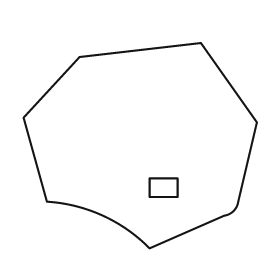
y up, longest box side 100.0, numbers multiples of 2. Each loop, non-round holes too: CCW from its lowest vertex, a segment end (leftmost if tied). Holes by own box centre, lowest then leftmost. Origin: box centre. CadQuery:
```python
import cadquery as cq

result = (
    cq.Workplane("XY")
    .moveTo(4.0, -44.0)
    .lineTo(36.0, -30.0)
    .threePointArc((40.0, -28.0), (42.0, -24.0))
    .lineTo(50.0, 10.0)
    .lineTo(26.0, 44.0)
    .lineTo(-26.0, 38.0)
    .lineTo(-50.0, 12.0)
    .lineTo(-40.0, -24.0)
    .threePointArc((-16.0, -30.0), (4.0, -44.0))
    .close()
    .moveTo(4.0, -22.0)
    .lineTo(16.0, -22.0)
    .lineTo(16.0, -14.0)
    .lineTo(4.0, -14.0)
    .close()
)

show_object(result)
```